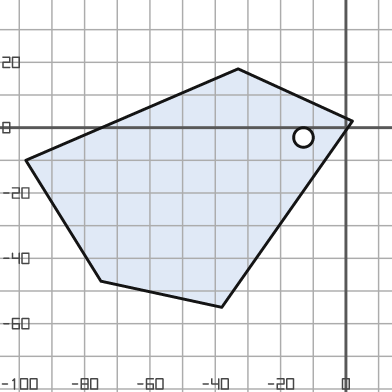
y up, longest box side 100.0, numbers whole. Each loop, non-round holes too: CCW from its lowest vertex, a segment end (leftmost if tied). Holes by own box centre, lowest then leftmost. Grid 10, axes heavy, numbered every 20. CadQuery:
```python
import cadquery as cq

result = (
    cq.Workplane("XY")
    .moveTo(-38.0, -55.0)
    .lineTo(2.0, 2.0)
    .lineTo(-33.0, 18.0)
    .lineTo(-98.0, -10.0)
    .lineTo(-75.0, -47.0)
    .close()
    .moveTo(-13.0, -3.0)
    .circle(3.0)
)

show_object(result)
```